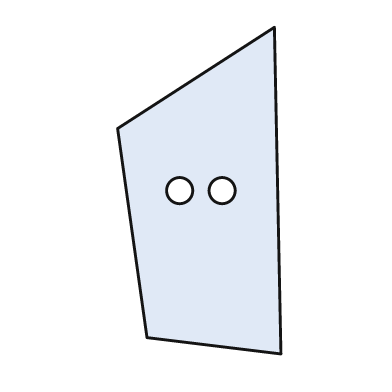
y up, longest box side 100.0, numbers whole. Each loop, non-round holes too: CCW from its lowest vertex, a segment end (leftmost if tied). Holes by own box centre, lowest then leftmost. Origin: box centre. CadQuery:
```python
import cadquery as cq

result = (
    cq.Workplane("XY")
    .moveTo(25.0, -50.0)
    .lineTo(23.0, 50.0)
    .lineTo(-25.0, 19.0)
    .lineTo(-16.0, -45.0)
    .close()
    .moveTo(-6.0, 0.0)
    .circle(4.0)
    .moveTo(7.0, 0.0)
    .circle(4.0)
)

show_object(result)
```